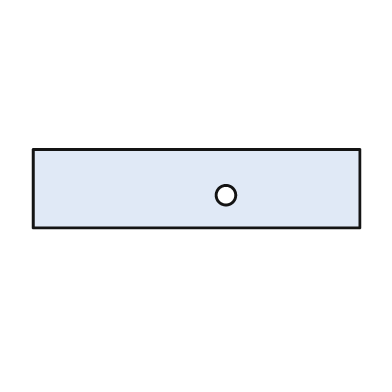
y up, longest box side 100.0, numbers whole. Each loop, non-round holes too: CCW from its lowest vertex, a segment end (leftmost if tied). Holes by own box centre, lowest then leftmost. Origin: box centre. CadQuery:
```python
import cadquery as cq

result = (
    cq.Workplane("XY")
    .moveTo(-50.0, -12.0)
    .lineTo(50.0, -12.0)
    .lineTo(50.0, 12.0)
    .lineTo(-50.0, 12.0)
    .close()
    .moveTo(9.0, -2.0)
    .circle(3.0)
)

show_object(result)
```